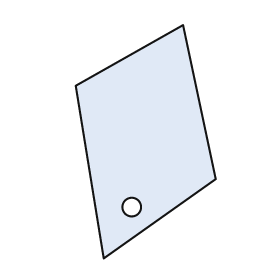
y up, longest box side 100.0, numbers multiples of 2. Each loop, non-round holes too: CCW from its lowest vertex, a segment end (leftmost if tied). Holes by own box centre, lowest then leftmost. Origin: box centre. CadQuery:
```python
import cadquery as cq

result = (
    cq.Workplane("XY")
    .moveTo(-18.0, -50.0)
    .lineTo(30.0, -16.0)
    .lineTo(16.0, 50.0)
    .lineTo(-30.0, 24.0)
    .close()
    .moveTo(-6.0, -28.0)
    .circle(4.0)
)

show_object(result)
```